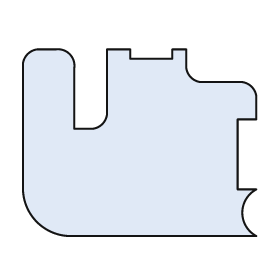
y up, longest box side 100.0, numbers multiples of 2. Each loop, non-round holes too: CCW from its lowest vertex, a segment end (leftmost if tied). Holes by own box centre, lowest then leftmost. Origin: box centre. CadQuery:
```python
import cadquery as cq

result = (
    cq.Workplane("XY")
    .moveTo(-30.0, -40.0)
    .lineTo(50.0, -40.0)
    .threePointArc((44.0, -30.0), (50.0, -20.0))
    .lineTo(42.0, -20.0)
    .lineTo(42.0, 10.0)
    .lineTo(50.0, 10.0)
    .lineTo(50.0, 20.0)
    .threePointArc((48.0, 24.0), (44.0, 26.0))
    .lineTo(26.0, 26.0)
    .threePointArc((22.0, 28.0), (20.0, 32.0))
    .lineTo(20.0, 40.0)
    .lineTo(14.0, 40.0)
    .lineTo(14.0, 36.0)
    .lineTo(-4.0, 36.0)
    .lineTo(-4.0, 40.0)
    .lineTo(-14.0, 40.0)
    .lineTo(-14.0, 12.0)
    .threePointArc((-16.0, 8.0), (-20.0, 6.0))
    .lineTo(-28.0, 6.0)
    .lineTo(-28.0, 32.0)
    .threePointArc((-30.0, 38.0), (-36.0, 40.0))
    .lineTo(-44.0, 40.0)
    .threePointArc((-48.0, 38.0), (-50.0, 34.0))
    .lineTo(-50.0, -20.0)
    .threePointArc((-44.0, -34.0), (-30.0, -40.0))
    .close()
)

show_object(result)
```